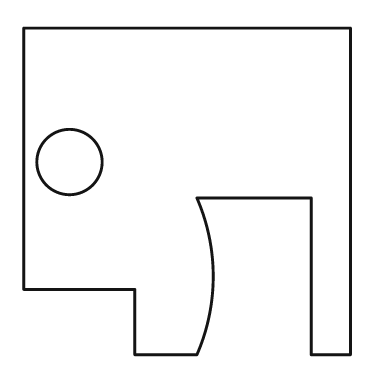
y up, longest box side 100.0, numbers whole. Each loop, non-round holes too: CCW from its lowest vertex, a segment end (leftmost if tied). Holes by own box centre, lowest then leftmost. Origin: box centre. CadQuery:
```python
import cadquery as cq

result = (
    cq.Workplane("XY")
    .moveTo(-16.0, -50.0)
    .lineTo(3.0, -50.0)
    .threePointArc((8.0, -26.0), (3.0, -2.0))
    .lineTo(38.0, -2.0)
    .lineTo(38.0, -50.0)
    .lineTo(50.0, -50.0)
    .lineTo(50.0, 50.0)
    .lineTo(-50.0, 50.0)
    .lineTo(-50.0, -30.0)
    .lineTo(-16.0, -30.0)
    .close()
    .moveTo(-36.0, 9.0)
    .circle(10.0)
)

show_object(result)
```